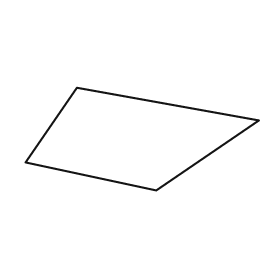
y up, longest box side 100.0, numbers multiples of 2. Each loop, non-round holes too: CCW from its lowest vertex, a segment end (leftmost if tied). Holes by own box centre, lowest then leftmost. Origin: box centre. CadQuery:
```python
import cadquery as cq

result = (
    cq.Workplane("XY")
    .moveTo(6.0, -22.0)
    .lineTo(50.0, 8.0)
    .lineTo(-28.0, 22.0)
    .lineTo(-50.0, -10.0)
    .close()
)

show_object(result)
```